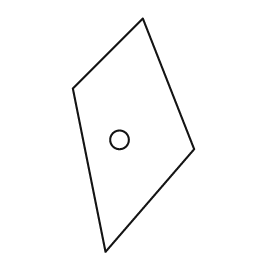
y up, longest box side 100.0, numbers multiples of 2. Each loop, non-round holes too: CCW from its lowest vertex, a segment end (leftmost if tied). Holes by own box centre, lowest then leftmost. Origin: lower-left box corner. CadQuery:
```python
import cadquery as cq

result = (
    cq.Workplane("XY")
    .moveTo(14.0, 0.0)
    .lineTo(52.0, 44.0)
    .lineTo(30.0, 100.0)
    .lineTo(0.0, 70.0)
    .close()
    .moveTo(20.0, 48.0)
    .circle(4.0)
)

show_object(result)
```